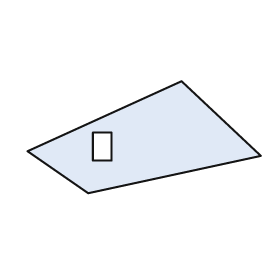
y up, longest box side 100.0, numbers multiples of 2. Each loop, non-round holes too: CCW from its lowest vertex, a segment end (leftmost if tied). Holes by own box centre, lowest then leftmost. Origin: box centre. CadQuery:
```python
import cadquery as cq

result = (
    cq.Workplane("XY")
    .moveTo(-24.0, -24.0)
    .lineTo(50.0, -8.0)
    .lineTo(16.0, 24.0)
    .lineTo(-50.0, -6.0)
    .close()
    .moveTo(-22.0, -10.0)
    .lineTo(-14.0, -10.0)
    .lineTo(-14.0, 2.0)
    .lineTo(-22.0, 2.0)
    .close()
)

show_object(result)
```